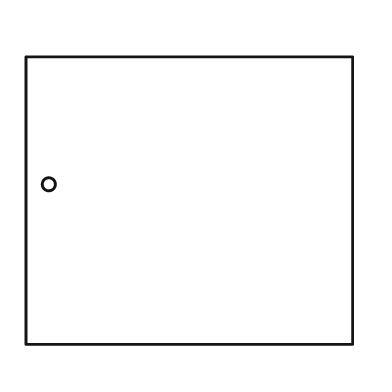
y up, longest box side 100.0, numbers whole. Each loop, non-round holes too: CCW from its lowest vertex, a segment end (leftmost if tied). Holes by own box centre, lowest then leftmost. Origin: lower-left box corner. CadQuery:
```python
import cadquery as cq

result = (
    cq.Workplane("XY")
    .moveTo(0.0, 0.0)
    .lineTo(100.0, 0.0)
    .lineTo(100.0, 88.0)
    .lineTo(0.0, 88.0)
    .close()
    .moveTo(7.0, 49.0)
    .circle(2.0)
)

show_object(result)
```